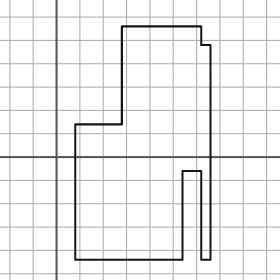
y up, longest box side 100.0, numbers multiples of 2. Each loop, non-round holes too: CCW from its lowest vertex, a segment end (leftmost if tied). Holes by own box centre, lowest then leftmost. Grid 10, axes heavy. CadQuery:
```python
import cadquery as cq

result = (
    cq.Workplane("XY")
    .moveTo(8.0, -44.0)
    .lineTo(54.0, -44.0)
    .lineTo(54.0, -6.0)
    .lineTo(62.0, -6.0)
    .lineTo(62.0, -44.0)
    .lineTo(66.0, -44.0)
    .lineTo(66.0, 48.0)
    .lineTo(62.0, 48.0)
    .lineTo(62.0, 56.0)
    .lineTo(28.0, 56.0)
    .lineTo(28.0, 14.0)
    .lineTo(8.0, 14.0)
    .close()
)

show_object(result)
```